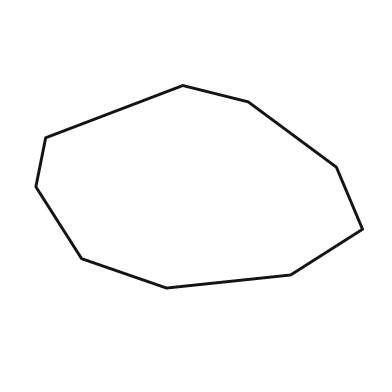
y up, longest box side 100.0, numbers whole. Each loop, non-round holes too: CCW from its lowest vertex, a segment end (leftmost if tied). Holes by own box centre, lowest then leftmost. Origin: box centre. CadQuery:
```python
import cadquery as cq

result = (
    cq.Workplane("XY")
    .moveTo(-10.0, -31.0)
    .lineTo(28.0, -27.0)
    .lineTo(50.0, -13.0)
    .lineTo(42.0, 6.0)
    .lineTo(15.0, 26.0)
    .lineTo(-5.0, 31.0)
    .lineTo(-47.0, 15.0)
    .lineTo(-50.0, 0.0)
    .lineTo(-36.0, -22.0)
    .close()
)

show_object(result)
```